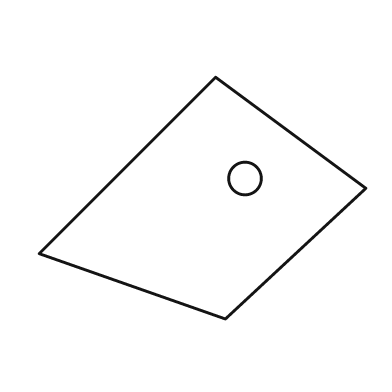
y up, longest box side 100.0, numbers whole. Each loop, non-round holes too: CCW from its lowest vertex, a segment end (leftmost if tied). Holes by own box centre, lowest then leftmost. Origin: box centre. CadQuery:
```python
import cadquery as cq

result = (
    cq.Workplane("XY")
    .moveTo(7.0, -37.0)
    .lineTo(50.0, 3.0)
    .lineTo(4.0, 37.0)
    .lineTo(-50.0, -17.0)
    .close()
    .moveTo(13.0, 6.0)
    .circle(5.0)
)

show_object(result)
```